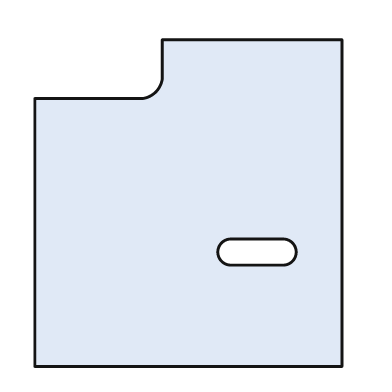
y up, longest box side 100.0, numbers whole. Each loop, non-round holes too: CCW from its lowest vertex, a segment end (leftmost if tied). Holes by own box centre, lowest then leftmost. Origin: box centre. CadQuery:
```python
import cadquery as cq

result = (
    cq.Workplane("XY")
    .moveTo(-47.0, -50.0)
    .lineTo(47.0, -50.0)
    .lineTo(47.0, 50.0)
    .lineTo(-8.0, 50.0)
    .lineTo(-8.0, 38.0)
    .threePointArc((-10.0, 34.0), (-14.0, 32.0))
    .lineTo(-47.0, 32.0)
    .close()
    .moveTo(13.0, -19.0)
    .lineTo(29.0, -19.0)
    .threePointArc((33.0, -15.0), (29.0, -11.0))
    .lineTo(13.0, -11.0)
    .threePointArc((9.0, -15.0), (13.0, -19.0))
    .close()
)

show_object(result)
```